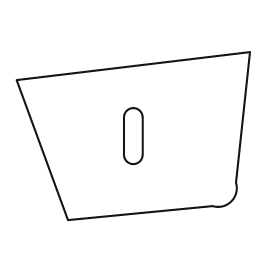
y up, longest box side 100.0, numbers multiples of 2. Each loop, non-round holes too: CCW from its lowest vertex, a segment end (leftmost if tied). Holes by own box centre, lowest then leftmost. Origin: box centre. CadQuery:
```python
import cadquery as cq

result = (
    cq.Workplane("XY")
    .moveTo(-28.0, -36.0)
    .lineTo(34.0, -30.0)
    .threePointArc((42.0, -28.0), (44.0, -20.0))
    .lineTo(50.0, 36.0)
    .lineTo(-50.0, 24.0)
    .close()
    .moveTo(-4.0, -8.0)
    .threePointArc((0.0, -12.0), (4.0, -8.0))
    .lineTo(4.0, 8.0)
    .threePointArc((0.0, 12.0), (-4.0, 8.0))
    .close()
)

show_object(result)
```